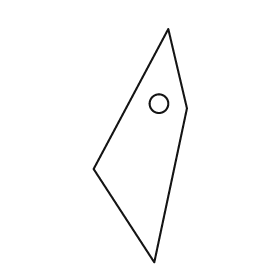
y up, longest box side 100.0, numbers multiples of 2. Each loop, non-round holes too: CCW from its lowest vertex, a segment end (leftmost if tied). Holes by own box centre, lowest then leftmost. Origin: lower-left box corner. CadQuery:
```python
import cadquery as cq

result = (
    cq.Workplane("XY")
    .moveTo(26.0, 0.0)
    .lineTo(40.0, 66.0)
    .lineTo(32.0, 100.0)
    .lineTo(0.0, 40.0)
    .close()
    .moveTo(28.0, 68.0)
    .circle(4.0)
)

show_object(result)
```